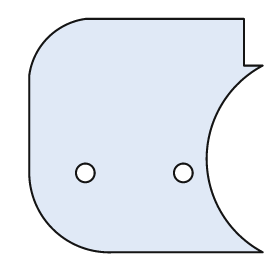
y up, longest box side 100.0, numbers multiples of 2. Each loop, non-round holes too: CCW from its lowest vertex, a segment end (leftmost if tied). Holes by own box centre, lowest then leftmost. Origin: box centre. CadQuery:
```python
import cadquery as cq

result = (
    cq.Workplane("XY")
    .moveTo(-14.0, -50.0)
    .lineTo(50.0, -50.0)
    .threePointArc((26.0, -10.0), (50.0, 30.0))
    .lineTo(42.0, 30.0)
    .lineTo(42.0, 50.0)
    .lineTo(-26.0, 50.0)
    .threePointArc((-42.0, 42.0), (-50.0, 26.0))
    .lineTo(-50.0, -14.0)
    .threePointArc((-40.0, -40.0), (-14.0, -50.0))
    .close()
    .moveTo(-26.0, -16.0)
    .circle(4.0)
    .moveTo(16.0, -16.0)
    .circle(4.0)
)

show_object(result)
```